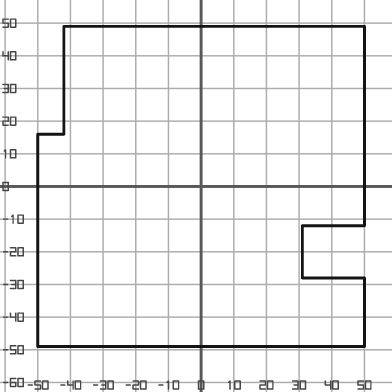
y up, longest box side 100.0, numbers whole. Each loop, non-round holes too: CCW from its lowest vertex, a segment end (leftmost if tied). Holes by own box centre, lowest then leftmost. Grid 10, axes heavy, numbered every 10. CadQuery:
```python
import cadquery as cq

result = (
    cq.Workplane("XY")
    .moveTo(-50.0, -49.0)
    .lineTo(50.0, -49.0)
    .lineTo(50.0, -28.0)
    .lineTo(31.0, -28.0)
    .lineTo(31.0, -12.0)
    .lineTo(50.0, -12.0)
    .lineTo(50.0, 49.0)
    .lineTo(-42.0, 49.0)
    .lineTo(-42.0, 16.0)
    .lineTo(-50.0, 16.0)
    .close()
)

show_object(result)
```